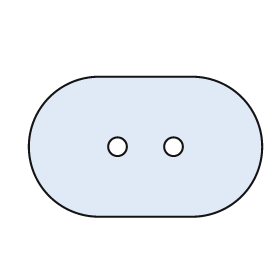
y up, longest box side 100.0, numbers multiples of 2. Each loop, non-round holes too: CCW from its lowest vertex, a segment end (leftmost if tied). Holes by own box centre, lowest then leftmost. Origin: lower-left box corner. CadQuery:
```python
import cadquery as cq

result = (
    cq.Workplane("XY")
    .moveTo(30.0, 0.0)
    .lineTo(70.0, 0.0)
    .threePointArc((100.0, 30.0), (70.0, 60.0))
    .lineTo(30.0, 60.0)
    .threePointArc((0.0, 30.0), (30.0, 0.0))
    .close()
    .moveTo(38.0, 30.0)
    .circle(4.0)
    .moveTo(62.0, 30.0)
    .circle(4.0)
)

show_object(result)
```